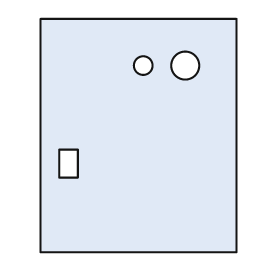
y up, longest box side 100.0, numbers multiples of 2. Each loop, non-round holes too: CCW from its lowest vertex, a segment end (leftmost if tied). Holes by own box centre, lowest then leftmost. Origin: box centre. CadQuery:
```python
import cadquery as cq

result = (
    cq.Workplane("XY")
    .moveTo(-42.0, -50.0)
    .lineTo(42.0, -50.0)
    .lineTo(42.0, 50.0)
    .lineTo(-42.0, 50.0)
    .close()
    .moveTo(-34.0, -18.0)
    .lineTo(-26.0, -18.0)
    .lineTo(-26.0, -6.0)
    .lineTo(-34.0, -6.0)
    .close()
    .moveTo(2.0, 30.0)
    .circle(4.0)
    .moveTo(20.0, 30.0)
    .circle(6.0)
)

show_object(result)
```